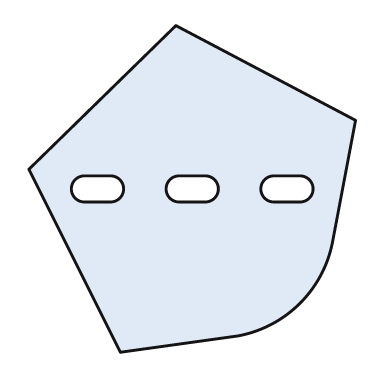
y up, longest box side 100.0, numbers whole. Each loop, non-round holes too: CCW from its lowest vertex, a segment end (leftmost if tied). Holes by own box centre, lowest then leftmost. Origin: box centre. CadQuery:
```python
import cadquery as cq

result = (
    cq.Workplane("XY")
    .moveTo(-22.0, -50.0)
    .lineTo(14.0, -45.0)
    .threePointArc((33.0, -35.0), (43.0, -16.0))
    .lineTo(50.0, 21.0)
    .lineTo(-5.0, 50.0)
    .lineTo(-50.0, 6.0)
    .close()
    .moveTo(-33.0, -4.0)
    .lineTo(-25.0, -4.0)
    .threePointArc((-21.0, 0.0), (-25.0, 4.0))
    .lineTo(-33.0, 4.0)
    .threePointArc((-37.0, 0.0), (-33.0, -4.0))
    .close()
    .moveTo(-4.0, -4.0)
    .lineTo(4.0, -4.0)
    .threePointArc((8.0, 0.0), (4.0, 4.0))
    .lineTo(-4.0, 4.0)
    .threePointArc((-8.0, 0.0), (-4.0, -4.0))
    .close()
    .moveTo(25.0, -4.0)
    .lineTo(33.0, -4.0)
    .threePointArc((37.0, 0.0), (33.0, 4.0))
    .lineTo(25.0, 4.0)
    .threePointArc((21.0, 0.0), (25.0, -4.0))
    .close()
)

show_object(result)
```